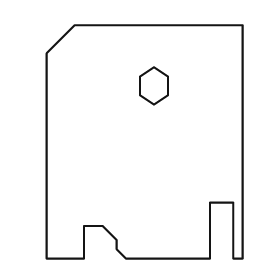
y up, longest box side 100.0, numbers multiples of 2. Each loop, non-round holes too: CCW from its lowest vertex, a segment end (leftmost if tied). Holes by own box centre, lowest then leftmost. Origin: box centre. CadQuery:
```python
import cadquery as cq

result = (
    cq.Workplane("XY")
    .moveTo(-42.0, -50.0)
    .lineTo(-26.0, -50.0)
    .lineTo(-26.0, -36.0)
    .lineTo(-18.0, -36.0)
    .lineTo(-12.0, -42.0)
    .lineTo(-12.0, -46.0)
    .lineTo(-8.0, -50.0)
    .lineTo(28.0, -50.0)
    .lineTo(28.0, -26.0)
    .lineTo(38.0, -26.0)
    .lineTo(38.0, -50.0)
    .lineTo(42.0, -50.0)
    .lineTo(42.0, 50.0)
    .lineTo(-30.0, 50.0)
    .lineTo(-42.0, 38.0)
    .close()
    .moveTo(4.0, 16.0)
    .lineTo(10.0, 20.0)
    .lineTo(10.0, 28.0)
    .lineTo(4.0, 32.0)
    .lineTo(-2.0, 28.0)
    .lineTo(-2.0, 20.0)
    .close()
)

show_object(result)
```